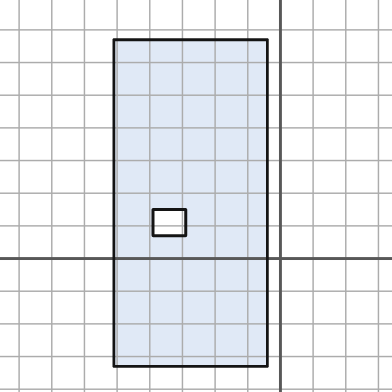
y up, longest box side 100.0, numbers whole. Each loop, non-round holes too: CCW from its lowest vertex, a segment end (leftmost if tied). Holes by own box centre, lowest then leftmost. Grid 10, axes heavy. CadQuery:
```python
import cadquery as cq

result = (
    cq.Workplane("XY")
    .moveTo(-51.0, -33.0)
    .lineTo(-4.0, -33.0)
    .lineTo(-4.0, 67.0)
    .lineTo(-51.0, 67.0)
    .close()
    .moveTo(-39.0, 7.0)
    .lineTo(-29.0, 7.0)
    .lineTo(-29.0, 15.0)
    .lineTo(-39.0, 15.0)
    .close()
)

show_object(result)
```